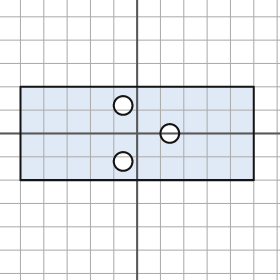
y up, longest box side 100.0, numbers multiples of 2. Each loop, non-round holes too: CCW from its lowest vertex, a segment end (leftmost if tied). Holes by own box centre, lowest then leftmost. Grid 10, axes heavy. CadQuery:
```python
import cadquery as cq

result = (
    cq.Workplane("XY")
    .moveTo(-50.0, -20.0)
    .lineTo(50.0, -20.0)
    .lineTo(50.0, 20.0)
    .lineTo(-50.0, 20.0)
    .close()
    .moveTo(-6.0, -12.0)
    .circle(4.0)
    .moveTo(14.0, 0.0)
    .circle(4.0)
    .moveTo(-6.0, 12.0)
    .circle(4.0)
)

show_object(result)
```